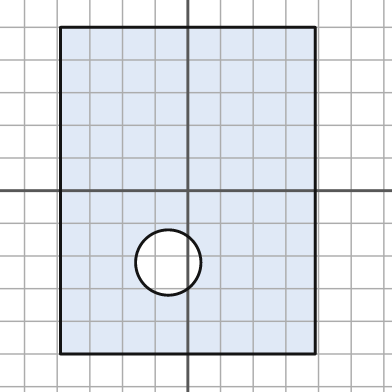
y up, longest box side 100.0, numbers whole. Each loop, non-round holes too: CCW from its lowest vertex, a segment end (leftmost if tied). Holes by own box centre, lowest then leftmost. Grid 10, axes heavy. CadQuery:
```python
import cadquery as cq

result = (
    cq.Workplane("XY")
    .moveTo(-39.0, -50.0)
    .lineTo(39.0, -50.0)
    .lineTo(39.0, 50.0)
    .lineTo(-39.0, 50.0)
    .close()
    .moveTo(-6.0, -22.0)
    .circle(10.0)
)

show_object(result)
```